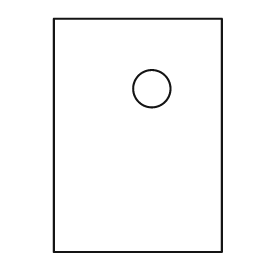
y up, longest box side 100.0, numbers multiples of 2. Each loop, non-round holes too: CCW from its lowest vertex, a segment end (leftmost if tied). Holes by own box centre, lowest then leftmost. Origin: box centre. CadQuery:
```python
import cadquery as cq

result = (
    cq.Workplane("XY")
    .moveTo(-36.0, -50.0)
    .lineTo(36.0, -50.0)
    .lineTo(36.0, 50.0)
    .lineTo(-36.0, 50.0)
    .close()
    .moveTo(6.0, 20.0)
    .circle(8.0)
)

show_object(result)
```